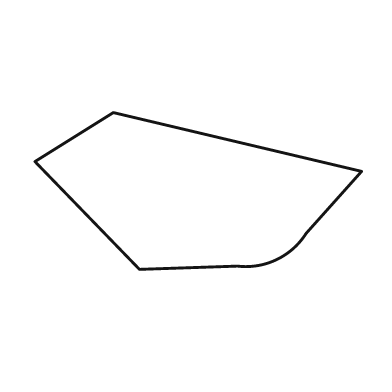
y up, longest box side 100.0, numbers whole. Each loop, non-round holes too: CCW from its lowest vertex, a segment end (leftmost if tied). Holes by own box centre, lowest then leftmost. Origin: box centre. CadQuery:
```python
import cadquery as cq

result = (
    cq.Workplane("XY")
    .moveTo(-18.0, -24.0)
    .lineTo(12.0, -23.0)
    .threePointArc((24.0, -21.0), (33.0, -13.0))
    .lineTo(50.0, 6.0)
    .lineTo(-26.0, 24.0)
    .lineTo(-50.0, 9.0)
    .close()
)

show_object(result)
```